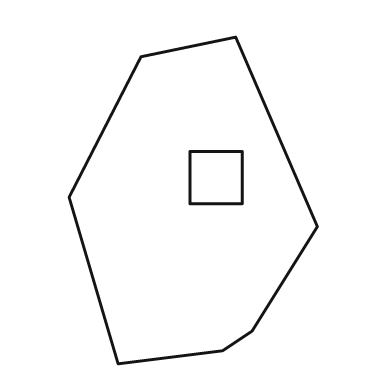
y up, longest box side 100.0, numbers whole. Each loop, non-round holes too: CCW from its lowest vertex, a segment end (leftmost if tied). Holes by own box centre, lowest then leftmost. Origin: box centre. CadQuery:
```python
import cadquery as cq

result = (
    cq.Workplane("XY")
    .moveTo(-23.0, -50.0)
    .lineTo(9.0, -46.0)
    .lineTo(18.0, -40.0)
    .lineTo(38.0, -8.0)
    .lineTo(13.0, 50.0)
    .lineTo(-16.0, 44.0)
    .lineTo(-38.0, 1.0)
    .close()
    .moveTo(-1.0, -1.0)
    .lineTo(15.0, -1.0)
    .lineTo(15.0, 15.0)
    .lineTo(-1.0, 15.0)
    .close()
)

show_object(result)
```